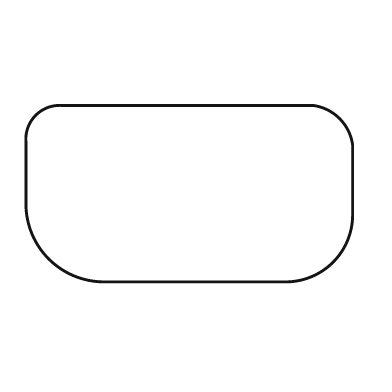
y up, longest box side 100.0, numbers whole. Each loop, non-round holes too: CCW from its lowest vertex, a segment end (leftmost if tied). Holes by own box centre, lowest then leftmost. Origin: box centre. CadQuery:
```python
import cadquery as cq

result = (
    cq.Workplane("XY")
    .moveTo(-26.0, -27.0)
    .lineTo(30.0, -27.0)
    .threePointArc((44.0, -21.0), (50.0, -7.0))
    .lineTo(50.0, 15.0)
    .threePointArc((46.0, 23.0), (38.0, 27.0))
    .lineTo(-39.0, 27.0)
    .threePointArc((-47.0, 24.0), (-50.0, 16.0))
    .lineTo(-50.0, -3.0)
    .threePointArc((-43.0, -20.0), (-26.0, -27.0))
    .close()
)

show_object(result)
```